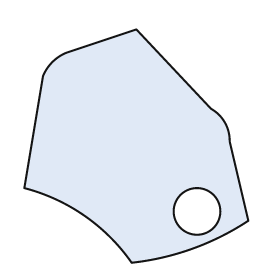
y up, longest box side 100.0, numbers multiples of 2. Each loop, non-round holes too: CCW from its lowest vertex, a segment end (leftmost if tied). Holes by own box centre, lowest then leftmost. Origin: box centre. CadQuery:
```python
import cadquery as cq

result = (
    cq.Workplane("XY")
    .moveTo(-2.0, -50.0)
    .threePointArc((24.0, -44.0), (48.0, -32.0))
    .lineTo(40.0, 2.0)
    .threePointArc((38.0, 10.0), (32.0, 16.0))
    .lineTo(0.0, 50.0)
    .lineTo(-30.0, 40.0)
    .threePointArc((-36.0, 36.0), (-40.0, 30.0))
    .lineTo(-48.0, -18.0)
    .threePointArc((-22.0, -30.0), (-2.0, -50.0))
    .close()
    .moveTo(26.0, -28.0)
    .circle(10.0)
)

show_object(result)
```